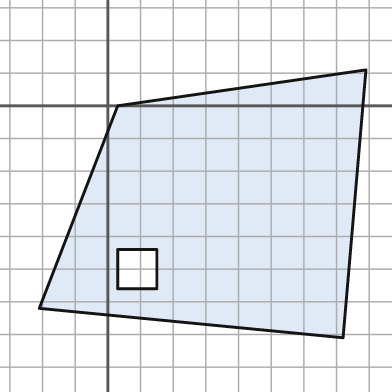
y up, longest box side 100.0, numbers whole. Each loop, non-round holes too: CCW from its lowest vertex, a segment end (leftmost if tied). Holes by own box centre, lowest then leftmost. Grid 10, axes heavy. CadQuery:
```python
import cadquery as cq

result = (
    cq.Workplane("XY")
    .moveTo(72.0, -71.0)
    .lineTo(79.0, 11.0)
    .lineTo(3.0, 0.0)
    .lineTo(-21.0, -62.0)
    .close()
    .moveTo(3.0, -56.0)
    .lineTo(15.0, -56.0)
    .lineTo(15.0, -44.0)
    .lineTo(3.0, -44.0)
    .close()
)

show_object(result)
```